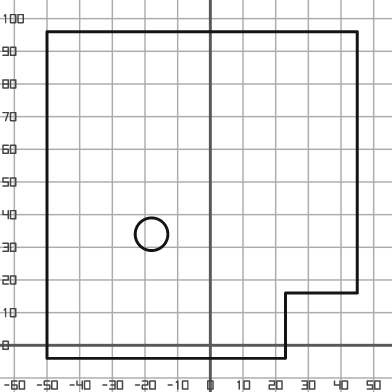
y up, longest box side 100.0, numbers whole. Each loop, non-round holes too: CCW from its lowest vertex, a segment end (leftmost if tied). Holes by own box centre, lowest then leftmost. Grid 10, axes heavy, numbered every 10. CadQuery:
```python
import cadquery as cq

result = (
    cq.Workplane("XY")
    .moveTo(-50.0, -4.0)
    .lineTo(23.0, -4.0)
    .lineTo(23.0, 16.0)
    .lineTo(45.0, 16.0)
    .lineTo(45.0, 96.0)
    .lineTo(-50.0, 96.0)
    .close()
    .moveTo(-18.0, 34.0)
    .circle(5.0)
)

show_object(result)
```